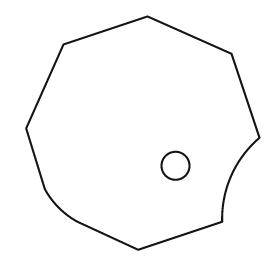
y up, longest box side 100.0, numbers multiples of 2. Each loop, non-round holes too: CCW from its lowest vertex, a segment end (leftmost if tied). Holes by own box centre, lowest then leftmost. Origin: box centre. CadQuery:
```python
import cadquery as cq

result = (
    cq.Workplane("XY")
    .moveTo(-2.0, -50.0)
    .lineTo(34.0, -38.0)
    .threePointArc((38.0, -18.0), (50.0, -2.0))
    .lineTo(38.0, 34.0)
    .lineTo(2.0, 50.0)
    .lineTo(-34.0, 38.0)
    .lineTo(-50.0, 2.0)
    .lineTo(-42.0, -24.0)
    .threePointArc((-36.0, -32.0), (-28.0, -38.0))
    .close()
    .moveTo(14.0, -14.0)
    .circle(6.0)
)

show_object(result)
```